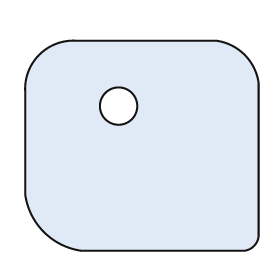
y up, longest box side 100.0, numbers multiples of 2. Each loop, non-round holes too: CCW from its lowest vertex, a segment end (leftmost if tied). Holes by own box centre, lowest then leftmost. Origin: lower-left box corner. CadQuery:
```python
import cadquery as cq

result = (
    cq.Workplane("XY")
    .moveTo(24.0, 0.0)
    .lineTo(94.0, 0.0)
    .threePointArc((98.0, 2.0), (100.0, 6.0))
    .lineTo(100.0, 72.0)
    .threePointArc((94.0, 84.0), (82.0, 90.0))
    .lineTo(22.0, 90.0)
    .threePointArc((6.0, 84.0), (0.0, 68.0))
    .lineTo(0.0, 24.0)
    .threePointArc((8.0, 8.0), (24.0, 0.0))
    .close()
    .moveTo(40.0, 62.0)
    .circle(8.0)
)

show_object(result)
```